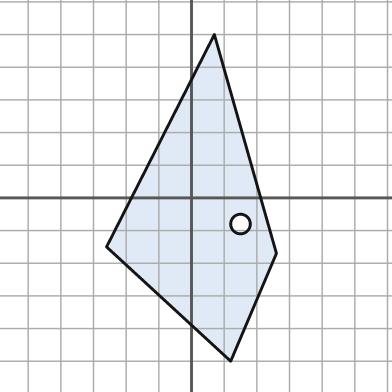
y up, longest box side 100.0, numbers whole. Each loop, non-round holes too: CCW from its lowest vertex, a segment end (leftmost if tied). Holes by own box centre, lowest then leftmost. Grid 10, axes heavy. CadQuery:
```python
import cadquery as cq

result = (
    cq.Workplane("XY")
    .moveTo(12.0, -50.0)
    .lineTo(26.0, -17.0)
    .lineTo(7.0, 50.0)
    .lineTo(-26.0, -15.0)
    .close()
    .moveTo(15.0, -8.0)
    .circle(3.0)
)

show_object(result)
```